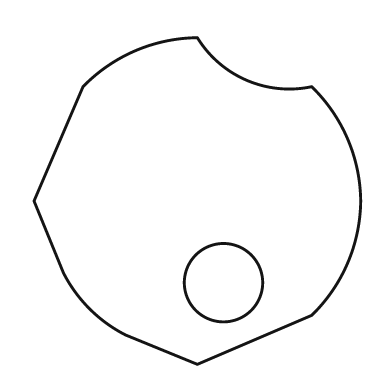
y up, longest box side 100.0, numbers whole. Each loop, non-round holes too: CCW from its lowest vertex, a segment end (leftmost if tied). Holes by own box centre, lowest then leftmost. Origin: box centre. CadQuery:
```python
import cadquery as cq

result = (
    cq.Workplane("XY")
    .moveTo(0.0, -50.0)
    .lineTo(35.0, -35.0)
    .threePointArc((46.0, -19.0), (50.0, 0.0))
    .threePointArc((46.0, 19.0), (35.0, 35.0))
    .threePointArc((15.0, 37.0), (0.0, 50.0))
    .threePointArc((-19.0, 46.0), (-35.0, 35.0))
    .lineTo(-50.0, 0.0)
    .lineTo(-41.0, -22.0)
    .threePointArc((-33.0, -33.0), (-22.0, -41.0))
    .close()
    .moveTo(8.0, -25.0)
    .circle(12.0)
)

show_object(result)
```